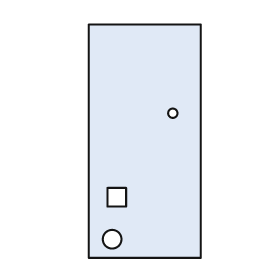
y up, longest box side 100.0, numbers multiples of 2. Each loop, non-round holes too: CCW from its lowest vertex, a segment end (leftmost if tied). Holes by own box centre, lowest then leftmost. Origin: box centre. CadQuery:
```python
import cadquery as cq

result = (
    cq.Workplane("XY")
    .moveTo(-24.0, -50.0)
    .lineTo(24.0, -50.0)
    .lineTo(24.0, 50.0)
    .lineTo(-24.0, 50.0)
    .close()
    .moveTo(-14.0, -42.0)
    .circle(4.0)
    .moveTo(-16.0, -28.0)
    .lineTo(-8.0, -28.0)
    .lineTo(-8.0, -20.0)
    .lineTo(-16.0, -20.0)
    .close()
    .moveTo(12.0, 12.0)
    .circle(2.0)
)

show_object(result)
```